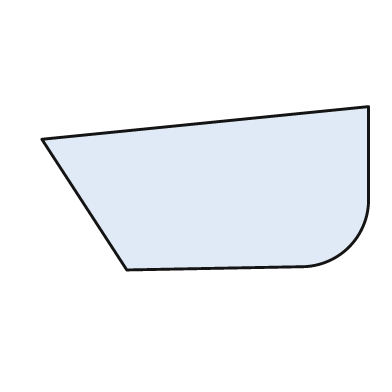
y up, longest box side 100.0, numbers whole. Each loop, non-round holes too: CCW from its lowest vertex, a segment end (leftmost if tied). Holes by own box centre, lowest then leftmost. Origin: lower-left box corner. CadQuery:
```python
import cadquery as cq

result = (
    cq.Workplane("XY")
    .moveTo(26.0, 0.0)
    .lineTo(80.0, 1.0)
    .threePointArc((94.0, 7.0), (100.0, 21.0))
    .lineTo(100.0, 50.0)
    .lineTo(0.0, 40.0)
    .close()
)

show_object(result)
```